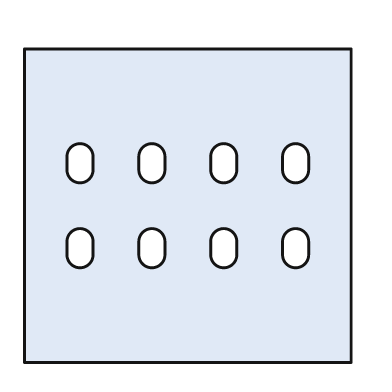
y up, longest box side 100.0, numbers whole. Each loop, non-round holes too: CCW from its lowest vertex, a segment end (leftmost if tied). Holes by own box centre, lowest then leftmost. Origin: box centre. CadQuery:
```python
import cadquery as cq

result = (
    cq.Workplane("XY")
    .moveTo(-50.0, -48.0)
    .lineTo(50.0, -48.0)
    .lineTo(50.0, 48.0)
    .lineTo(-50.0, 48.0)
    .close()
    .moveTo(-37.0, -15.0)
    .threePointArc((-33.0, -19.0), (-29.0, -15.0))
    .lineTo(-29.0, -11.0)
    .threePointArc((-33.0, -7.0), (-37.0, -11.0))
    .close()
    .moveTo(-15.0, -15.0)
    .threePointArc((-11.0, -19.0), (-7.0, -15.0))
    .lineTo(-7.0, -11.0)
    .threePointArc((-11.0, -7.0), (-15.0, -11.0))
    .close()
    .moveTo(7.0, -15.0)
    .threePointArc((11.0, -19.0), (15.0, -15.0))
    .lineTo(15.0, -11.0)
    .threePointArc((11.0, -7.0), (7.0, -11.0))
    .close()
    .moveTo(29.0, -15.0)
    .threePointArc((33.0, -19.0), (37.0, -15.0))
    .lineTo(37.0, -11.0)
    .threePointArc((33.0, -7.0), (29.0, -11.0))
    .close()
    .moveTo(-37.0, 11.0)
    .threePointArc((-33.0, 7.0), (-29.0, 11.0))
    .lineTo(-29.0, 15.0)
    .threePointArc((-33.0, 19.0), (-37.0, 15.0))
    .close()
    .moveTo(-15.0, 11.0)
    .threePointArc((-11.0, 7.0), (-7.0, 11.0))
    .lineTo(-7.0, 15.0)
    .threePointArc((-11.0, 19.0), (-15.0, 15.0))
    .close()
    .moveTo(7.0, 11.0)
    .threePointArc((11.0, 7.0), (15.0, 11.0))
    .lineTo(15.0, 15.0)
    .threePointArc((11.0, 19.0), (7.0, 15.0))
    .close()
    .moveTo(29.0, 11.0)
    .threePointArc((33.0, 7.0), (37.0, 11.0))
    .lineTo(37.0, 15.0)
    .threePointArc((33.0, 19.0), (29.0, 15.0))
    .close()
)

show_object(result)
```